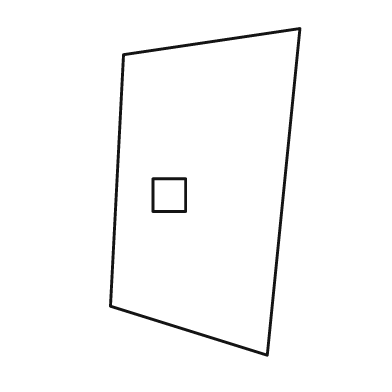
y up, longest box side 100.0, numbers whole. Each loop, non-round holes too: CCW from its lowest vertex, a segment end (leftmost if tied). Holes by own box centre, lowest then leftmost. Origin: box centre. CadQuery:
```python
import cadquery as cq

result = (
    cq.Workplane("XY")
    .moveTo(19.0, -50.0)
    .lineTo(29.0, 50.0)
    .lineTo(-25.0, 42.0)
    .lineTo(-29.0, -35.0)
    .close()
    .moveTo(-16.0, -6.0)
    .lineTo(-6.0, -6.0)
    .lineTo(-6.0, 4.0)
    .lineTo(-16.0, 4.0)
    .close()
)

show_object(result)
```